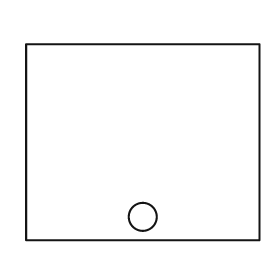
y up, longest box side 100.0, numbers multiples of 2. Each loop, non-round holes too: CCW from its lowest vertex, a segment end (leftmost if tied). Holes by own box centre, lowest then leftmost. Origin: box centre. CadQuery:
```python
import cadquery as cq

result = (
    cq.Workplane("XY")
    .moveTo(-50.0, -42.0)
    .lineTo(50.0, -42.0)
    .lineTo(50.0, 42.0)
    .lineTo(-50.0, 42.0)
    .close()
    .moveTo(0.0, -32.0)
    .circle(6.0)
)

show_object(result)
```